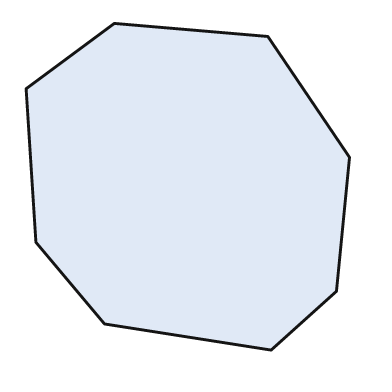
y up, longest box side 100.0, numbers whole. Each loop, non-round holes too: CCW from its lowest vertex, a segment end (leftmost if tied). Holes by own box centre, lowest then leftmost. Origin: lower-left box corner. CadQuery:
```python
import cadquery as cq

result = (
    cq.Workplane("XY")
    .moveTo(75.0, 0.0)
    .lineTo(95.0, 18.0)
    .lineTo(99.0, 59.0)
    .lineTo(74.0, 96.0)
    .lineTo(27.0, 100.0)
    .lineTo(0.0, 80.0)
    .lineTo(3.0, 33.0)
    .lineTo(24.0, 8.0)
    .close()
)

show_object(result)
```